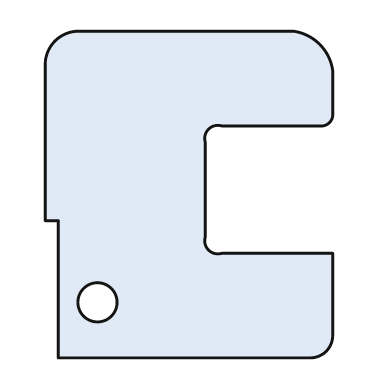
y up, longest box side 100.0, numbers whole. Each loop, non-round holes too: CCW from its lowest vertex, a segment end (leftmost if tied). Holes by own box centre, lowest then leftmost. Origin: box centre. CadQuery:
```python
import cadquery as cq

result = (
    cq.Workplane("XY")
    .moveTo(-40.0, -50.0)
    .lineTo(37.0, -50.0)
    .threePointArc((42.0, -48.0), (44.0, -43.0))
    .lineTo(44.0, -18.0)
    .lineTo(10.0, -18.0)
    .threePointArc((6.0, -17.0), (5.0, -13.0))
    .lineTo(5.0, 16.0)
    .threePointArc((6.0, 20.0), (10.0, 21.0))
    .lineTo(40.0, 21.0)
    .threePointArc((43.0, 22.0), (44.0, 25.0))
    .lineTo(44.0, 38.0)
    .threePointArc((40.0, 46.0), (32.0, 50.0))
    .lineTo(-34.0, 50.0)
    .threePointArc((-41.0, 47.0), (-44.0, 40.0))
    .lineTo(-44.0, -8.0)
    .lineTo(-40.0, -8.0)
    .close()
    .moveTo(-28.0, -33.0)
    .circle(6.0)
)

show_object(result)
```